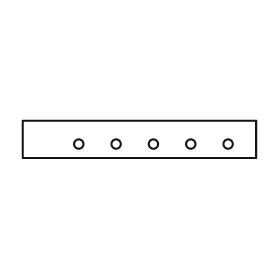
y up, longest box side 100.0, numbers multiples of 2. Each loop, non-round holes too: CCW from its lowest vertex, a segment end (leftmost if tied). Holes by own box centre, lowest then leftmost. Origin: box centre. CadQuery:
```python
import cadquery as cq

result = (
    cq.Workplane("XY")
    .moveTo(-50.0, -8.0)
    .lineTo(50.0, -8.0)
    .lineTo(50.0, 8.0)
    .lineTo(-50.0, 8.0)
    .close()
    .moveTo(-26.0, -2.0)
    .circle(2.0)
    .moveTo(-10.0, -2.0)
    .circle(2.0)
    .moveTo(6.0, -2.0)
    .circle(2.0)
    .moveTo(22.0, -2.0)
    .circle(2.0)
    .moveTo(38.0, -2.0)
    .circle(2.0)
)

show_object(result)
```